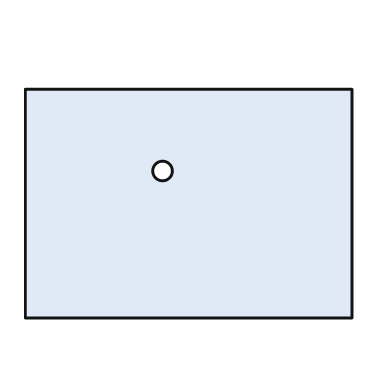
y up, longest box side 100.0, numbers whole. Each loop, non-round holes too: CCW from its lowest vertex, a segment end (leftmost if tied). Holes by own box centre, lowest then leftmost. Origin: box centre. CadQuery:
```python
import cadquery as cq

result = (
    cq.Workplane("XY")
    .moveTo(-50.0, -35.0)
    .lineTo(50.0, -35.0)
    .lineTo(50.0, 35.0)
    .lineTo(-50.0, 35.0)
    .close()
    .moveTo(-8.0, 10.0)
    .circle(3.0)
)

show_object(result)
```